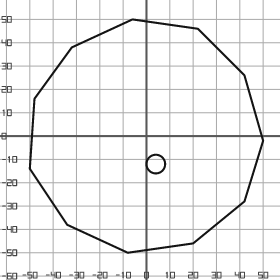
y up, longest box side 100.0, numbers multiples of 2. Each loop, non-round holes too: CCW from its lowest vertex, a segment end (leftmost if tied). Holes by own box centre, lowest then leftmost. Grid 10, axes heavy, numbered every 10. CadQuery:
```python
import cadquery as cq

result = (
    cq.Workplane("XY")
    .moveTo(-8.0, -50.0)
    .lineTo(20.0, -46.0)
    .lineTo(42.0, -28.0)
    .lineTo(50.0, -2.0)
    .lineTo(42.0, 26.0)
    .lineTo(22.0, 46.0)
    .lineTo(-6.0, 50.0)
    .lineTo(-32.0, 38.0)
    .lineTo(-48.0, 16.0)
    .lineTo(-50.0, -14.0)
    .lineTo(-34.0, -38.0)
    .close()
    .moveTo(4.0, -12.0)
    .circle(4.0)
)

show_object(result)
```